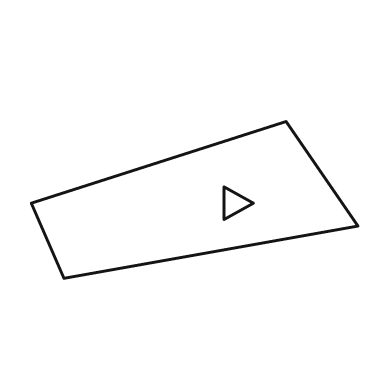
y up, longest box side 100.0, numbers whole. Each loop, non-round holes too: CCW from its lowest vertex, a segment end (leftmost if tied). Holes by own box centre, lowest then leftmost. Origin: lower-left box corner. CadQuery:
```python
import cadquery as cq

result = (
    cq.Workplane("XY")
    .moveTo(10.0, 0.0)
    .lineTo(100.0, 16.0)
    .lineTo(78.0, 48.0)
    .lineTo(0.0, 23.0)
    .close()
    .moveTo(59.0, 18.0)
    .lineTo(68.0, 23.0)
    .lineTo(59.0, 28.0)
    .close()
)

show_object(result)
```